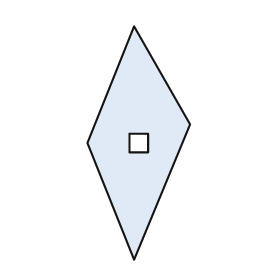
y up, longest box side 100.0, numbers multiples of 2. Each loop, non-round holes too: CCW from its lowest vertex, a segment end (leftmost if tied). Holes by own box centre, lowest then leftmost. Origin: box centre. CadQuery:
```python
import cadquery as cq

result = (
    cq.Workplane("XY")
    .moveTo(-2.0, -50.0)
    .lineTo(22.0, 8.0)
    .lineTo(-2.0, 50.0)
    .lineTo(-22.0, 0.0)
    .close()
    .moveTo(-4.0, -4.0)
    .lineTo(4.0, -4.0)
    .lineTo(4.0, 4.0)
    .lineTo(-4.0, 4.0)
    .close()
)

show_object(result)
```